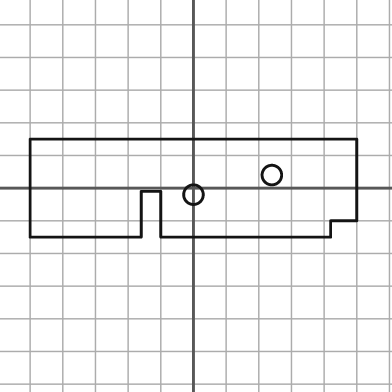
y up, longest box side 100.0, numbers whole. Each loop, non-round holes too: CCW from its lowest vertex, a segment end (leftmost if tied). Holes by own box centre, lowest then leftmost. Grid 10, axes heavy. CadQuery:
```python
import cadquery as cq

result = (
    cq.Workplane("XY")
    .moveTo(-50.0, -15.0)
    .lineTo(-16.0, -15.0)
    .lineTo(-16.0, -1.0)
    .lineTo(-10.0, -1.0)
    .lineTo(-10.0, -15.0)
    .lineTo(42.0, -15.0)
    .lineTo(42.0, -10.0)
    .lineTo(50.0, -10.0)
    .lineTo(50.0, 15.0)
    .lineTo(-50.0, 15.0)
    .close()
    .moveTo(0.0, -2.0)
    .circle(3.0)
    .moveTo(24.0, 4.0)
    .circle(3.0)
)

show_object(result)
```